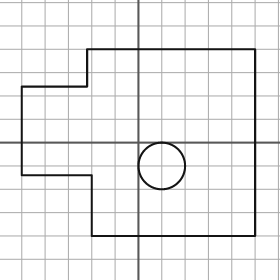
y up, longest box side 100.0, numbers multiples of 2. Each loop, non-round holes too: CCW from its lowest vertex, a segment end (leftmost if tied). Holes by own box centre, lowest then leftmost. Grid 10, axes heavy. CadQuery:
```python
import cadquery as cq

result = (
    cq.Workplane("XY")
    .moveTo(-20.0, -40.0)
    .lineTo(50.0, -40.0)
    .lineTo(50.0, 40.0)
    .lineTo(-22.0, 40.0)
    .lineTo(-22.0, 24.0)
    .lineTo(-50.0, 24.0)
    .lineTo(-50.0, -14.0)
    .lineTo(-20.0, -14.0)
    .close()
    .moveTo(10.0, -10.0)
    .circle(10.0)
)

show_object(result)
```